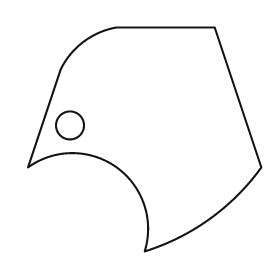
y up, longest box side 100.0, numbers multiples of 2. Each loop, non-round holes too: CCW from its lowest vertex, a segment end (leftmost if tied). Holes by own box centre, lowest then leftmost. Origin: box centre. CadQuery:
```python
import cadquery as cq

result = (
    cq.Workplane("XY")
    .moveTo(0.0, -48.0)
    .threePointArc((28.0, -34.0), (50.0, -12.0))
    .lineTo(30.0, 48.0)
    .lineTo(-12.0, 48.0)
    .threePointArc((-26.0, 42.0), (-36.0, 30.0))
    .lineTo(-50.0, -12.0)
    .threePointArc((-12.0, -12.0), (0.0, -48.0))
    .close()
    .moveTo(-32.0, 6.0)
    .circle(6.0)
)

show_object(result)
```